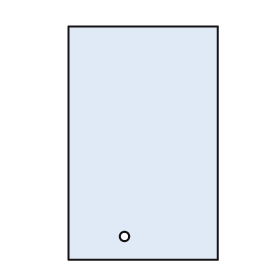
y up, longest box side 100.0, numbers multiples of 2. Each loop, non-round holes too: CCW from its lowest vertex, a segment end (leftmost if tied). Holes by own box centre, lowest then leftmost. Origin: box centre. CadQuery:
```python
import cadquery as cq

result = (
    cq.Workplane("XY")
    .moveTo(-32.0, -50.0)
    .lineTo(32.0, -50.0)
    .lineTo(32.0, 50.0)
    .lineTo(-32.0, 50.0)
    .close()
    .moveTo(-8.0, -40.0)
    .circle(2.0)
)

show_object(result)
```